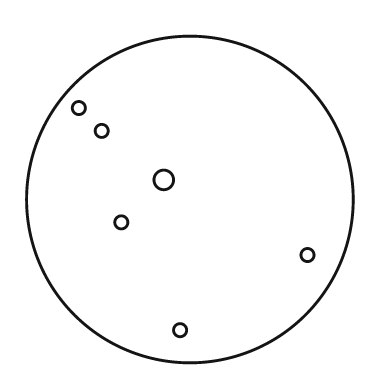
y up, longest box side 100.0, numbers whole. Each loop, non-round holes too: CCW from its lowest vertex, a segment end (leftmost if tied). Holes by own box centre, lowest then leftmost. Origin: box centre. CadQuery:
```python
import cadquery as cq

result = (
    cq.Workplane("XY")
    .moveTo(0.0, 0.0)
    .circle(50.0)
    .moveTo(-3.0, -40.0)
    .circle(2.0)
    .moveTo(36.0, -17.0)
    .circle(2.0)
    .moveTo(-21.0, -7.0)
    .circle(2.0)
    .moveTo(-8.0, 6.0)
    .circle(3.0)
    .moveTo(-27.0, 21.0)
    .circle(2.0)
    .moveTo(-34.0, 28.0)
    .circle(2.0)
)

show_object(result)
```